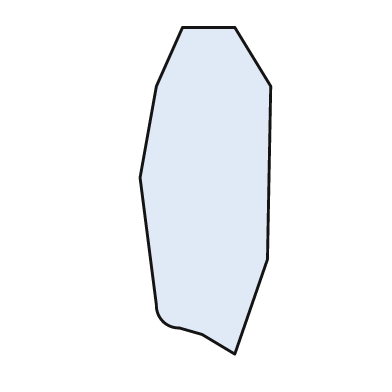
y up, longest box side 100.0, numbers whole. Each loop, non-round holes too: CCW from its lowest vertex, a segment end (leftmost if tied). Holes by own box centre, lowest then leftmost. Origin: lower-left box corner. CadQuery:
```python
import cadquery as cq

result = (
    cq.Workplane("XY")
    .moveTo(29.0, 0.0)
    .lineTo(39.0, 29.0)
    .lineTo(40.0, 82.0)
    .lineTo(29.0, 100.0)
    .lineTo(13.0, 100.0)
    .lineTo(5.0, 82.0)
    .lineTo(0.0, 54.0)
    .lineTo(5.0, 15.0)
    .threePointArc((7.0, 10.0), (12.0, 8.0))
    .lineTo(19.0, 6.0)
    .close()
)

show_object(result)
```